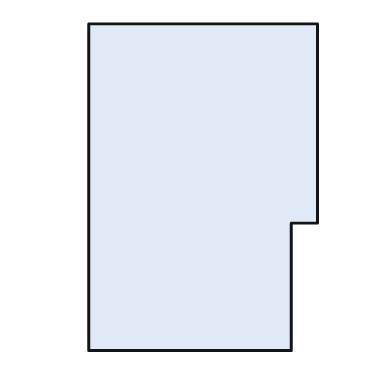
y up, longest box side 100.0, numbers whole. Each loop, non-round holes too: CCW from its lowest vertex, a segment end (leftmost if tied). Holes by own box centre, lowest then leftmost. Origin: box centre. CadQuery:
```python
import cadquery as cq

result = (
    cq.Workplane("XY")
    .moveTo(-35.0, -50.0)
    .lineTo(27.0, -50.0)
    .lineTo(27.0, -11.0)
    .lineTo(35.0, -11.0)
    .lineTo(35.0, 50.0)
    .lineTo(-35.0, 50.0)
    .close()
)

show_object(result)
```